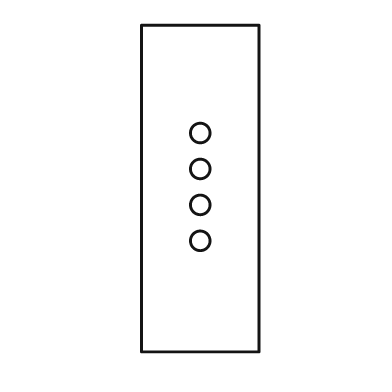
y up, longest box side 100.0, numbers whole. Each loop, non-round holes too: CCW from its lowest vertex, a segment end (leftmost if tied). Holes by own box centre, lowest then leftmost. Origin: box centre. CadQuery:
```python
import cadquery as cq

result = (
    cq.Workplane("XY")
    .moveTo(-18.0, -50.0)
    .lineTo(18.0, -50.0)
    .lineTo(18.0, 50.0)
    .lineTo(-18.0, 50.0)
    .close()
    .moveTo(0.0, -16.0)
    .circle(3.0)
    .moveTo(0.0, -5.0)
    .circle(3.0)
    .moveTo(0.0, 6.0)
    .circle(3.0)
    .moveTo(0.0, 17.0)
    .circle(3.0)
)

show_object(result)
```